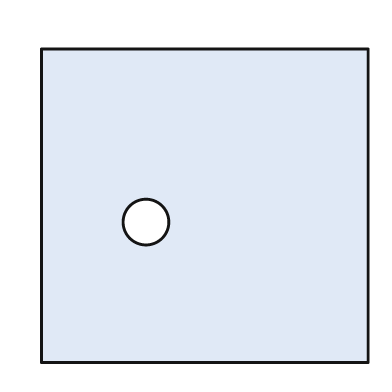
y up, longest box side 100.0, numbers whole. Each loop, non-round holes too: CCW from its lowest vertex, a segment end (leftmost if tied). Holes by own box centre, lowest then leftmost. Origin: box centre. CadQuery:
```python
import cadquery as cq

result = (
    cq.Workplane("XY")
    .moveTo(-50.0, -48.0)
    .lineTo(50.0, -48.0)
    .lineTo(50.0, 48.0)
    .lineTo(-50.0, 48.0)
    .close()
    .moveTo(-18.0, -5.0)
    .circle(7.0)
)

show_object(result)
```